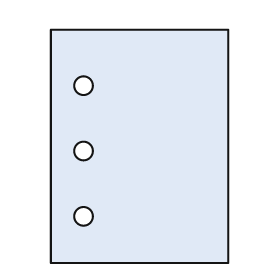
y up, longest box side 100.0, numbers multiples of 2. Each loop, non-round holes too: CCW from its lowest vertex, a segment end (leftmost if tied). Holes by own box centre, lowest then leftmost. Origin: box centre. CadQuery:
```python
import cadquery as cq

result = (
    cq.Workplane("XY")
    .moveTo(-38.0, -50.0)
    .lineTo(38.0, -50.0)
    .lineTo(38.0, 50.0)
    .lineTo(-38.0, 50.0)
    .close()
    .moveTo(-24.0, -30.0)
    .circle(4.0)
    .moveTo(-24.0, -2.0)
    .circle(4.0)
    .moveTo(-24.0, 26.0)
    .circle(4.0)
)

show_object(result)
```